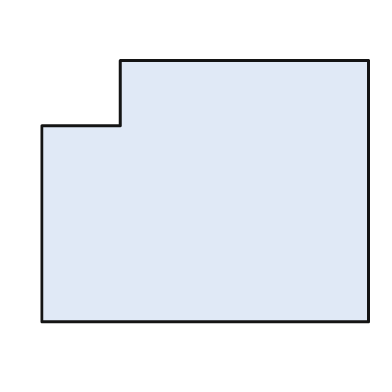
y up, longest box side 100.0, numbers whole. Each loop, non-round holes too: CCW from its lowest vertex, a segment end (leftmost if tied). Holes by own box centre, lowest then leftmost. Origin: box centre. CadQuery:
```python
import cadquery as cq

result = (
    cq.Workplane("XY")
    .moveTo(-50.0, -40.0)
    .lineTo(50.0, -40.0)
    .lineTo(50.0, 40.0)
    .lineTo(-26.0, 40.0)
    .lineTo(-26.0, 20.0)
    .lineTo(-50.0, 20.0)
    .close()
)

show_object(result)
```